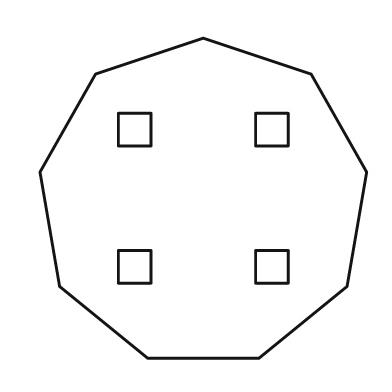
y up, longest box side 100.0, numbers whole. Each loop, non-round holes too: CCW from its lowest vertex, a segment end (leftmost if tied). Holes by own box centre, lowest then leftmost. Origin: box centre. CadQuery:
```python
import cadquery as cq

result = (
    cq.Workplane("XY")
    .moveTo(-17.0, -49.0)
    .lineTo(17.0, -49.0)
    .lineTo(44.0, -27.0)
    .lineTo(50.0, 8.0)
    .lineTo(33.0, 38.0)
    .lineTo(0.0, 49.0)
    .lineTo(-33.0, 38.0)
    .lineTo(-50.0, 8.0)
    .lineTo(-44.0, -27.0)
    .close()
    .moveTo(-26.0, -26.0)
    .lineTo(-16.0, -26.0)
    .lineTo(-16.0, -16.0)
    .lineTo(-26.0, -16.0)
    .close()
    .moveTo(16.0, -26.0)
    .lineTo(26.0, -26.0)
    .lineTo(26.0, -16.0)
    .lineTo(16.0, -16.0)
    .close()
    .moveTo(-26.0, 16.0)
    .lineTo(-16.0, 16.0)
    .lineTo(-16.0, 26.0)
    .lineTo(-26.0, 26.0)
    .close()
    .moveTo(16.0, 16.0)
    .lineTo(26.0, 16.0)
    .lineTo(26.0, 26.0)
    .lineTo(16.0, 26.0)
    .close()
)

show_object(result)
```